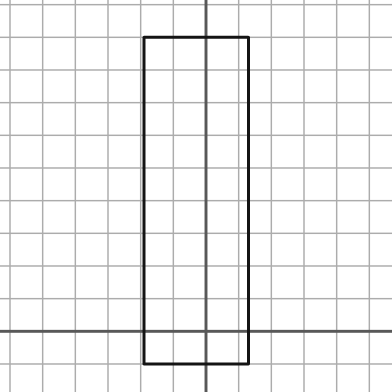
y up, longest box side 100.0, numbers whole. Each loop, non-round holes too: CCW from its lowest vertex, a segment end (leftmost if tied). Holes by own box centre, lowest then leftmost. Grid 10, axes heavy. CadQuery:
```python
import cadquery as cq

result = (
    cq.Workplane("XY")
    .moveTo(-19.0, -10.0)
    .lineTo(13.0, -10.0)
    .lineTo(13.0, 90.0)
    .lineTo(-19.0, 90.0)
    .close()
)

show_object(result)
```